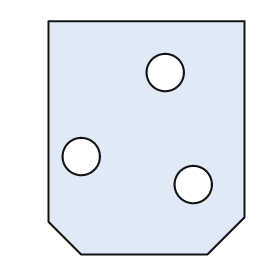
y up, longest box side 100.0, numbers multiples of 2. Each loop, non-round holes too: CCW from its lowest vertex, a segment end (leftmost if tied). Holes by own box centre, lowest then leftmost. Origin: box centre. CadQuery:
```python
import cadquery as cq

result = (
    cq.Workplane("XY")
    .moveTo(-28.0, -50.0)
    .lineTo(26.0, -50.0)
    .lineTo(42.0, -34.0)
    .lineTo(42.0, 50.0)
    .lineTo(-42.0, 50.0)
    .lineTo(-42.0, -36.0)
    .close()
    .moveTo(20.0, -20.0)
    .circle(8.0)
    .moveTo(-28.0, -8.0)
    .circle(8.0)
    .moveTo(8.0, 28.0)
    .circle(8.0)
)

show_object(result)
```